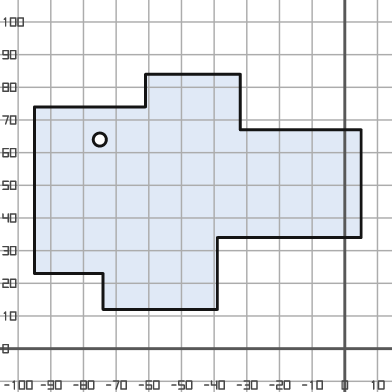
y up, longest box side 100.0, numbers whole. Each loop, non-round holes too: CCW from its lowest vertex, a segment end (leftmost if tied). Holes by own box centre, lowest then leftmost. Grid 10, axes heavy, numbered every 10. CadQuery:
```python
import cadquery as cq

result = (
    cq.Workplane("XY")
    .moveTo(-74.0, 12.0)
    .lineTo(-39.0, 12.0)
    .lineTo(-39.0, 34.0)
    .lineTo(5.0, 34.0)
    .lineTo(5.0, 67.0)
    .lineTo(-32.0, 67.0)
    .lineTo(-32.0, 84.0)
    .lineTo(-61.0, 84.0)
    .lineTo(-61.0, 74.0)
    .lineTo(-95.0, 74.0)
    .lineTo(-95.0, 23.0)
    .lineTo(-74.0, 23.0)
    .close()
    .moveTo(-75.0, 64.0)
    .circle(2.0)
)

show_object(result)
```